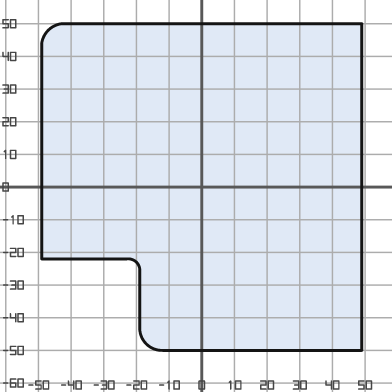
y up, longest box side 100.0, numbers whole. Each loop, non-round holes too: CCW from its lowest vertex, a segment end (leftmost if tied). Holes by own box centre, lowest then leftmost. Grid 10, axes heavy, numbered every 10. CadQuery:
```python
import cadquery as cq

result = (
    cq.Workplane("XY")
    .moveTo(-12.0, -50.0)
    .lineTo(49.0, -50.0)
    .lineTo(49.0, 50.0)
    .lineTo(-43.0, 50.0)
    .threePointArc((-47.0, 48.0), (-49.0, 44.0))
    .lineTo(-49.0, -22.0)
    .lineTo(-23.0, -22.0)
    .threePointArc((-20.0, -23.0), (-19.0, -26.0))
    .lineTo(-19.0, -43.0)
    .threePointArc((-17.0, -48.0), (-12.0, -50.0))
    .close()
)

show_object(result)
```